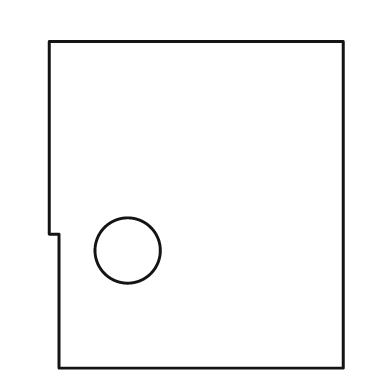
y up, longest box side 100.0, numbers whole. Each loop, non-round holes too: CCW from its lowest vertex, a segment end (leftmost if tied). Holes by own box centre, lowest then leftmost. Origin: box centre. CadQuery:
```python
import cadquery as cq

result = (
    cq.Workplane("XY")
    .moveTo(-42.0, -50.0)
    .lineTo(45.0, -50.0)
    .lineTo(45.0, 50.0)
    .lineTo(-45.0, 50.0)
    .lineTo(-45.0, -9.0)
    .lineTo(-42.0, -9.0)
    .close()
    .moveTo(-21.0, -14.0)
    .circle(10.0)
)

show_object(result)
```